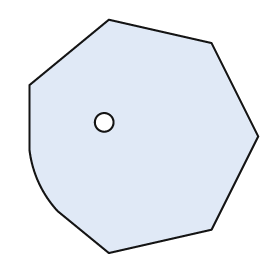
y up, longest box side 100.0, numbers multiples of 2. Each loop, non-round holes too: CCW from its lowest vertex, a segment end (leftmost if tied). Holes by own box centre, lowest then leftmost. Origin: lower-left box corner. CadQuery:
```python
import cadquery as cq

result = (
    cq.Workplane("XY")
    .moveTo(34.0, 0.0)
    .lineTo(78.0, 10.0)
    .lineTo(98.0, 50.0)
    .lineTo(78.0, 90.0)
    .lineTo(34.0, 100.0)
    .lineTo(0.0, 72.0)
    .lineTo(0.0, 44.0)
    .threePointArc((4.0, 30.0), (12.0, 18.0))
    .close()
    .moveTo(32.0, 56.0)
    .circle(4.0)
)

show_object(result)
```